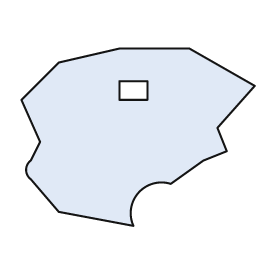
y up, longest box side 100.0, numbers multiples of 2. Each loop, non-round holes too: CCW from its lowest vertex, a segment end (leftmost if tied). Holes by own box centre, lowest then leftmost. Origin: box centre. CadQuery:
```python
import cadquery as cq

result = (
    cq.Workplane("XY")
    .moveTo(-2.0, -38.0)
    .threePointArc((0.0, -24.0), (14.0, -20.0))
    .lineTo(28.0, -10.0)
    .lineTo(38.0, -6.0)
    .lineTo(34.0, 4.0)
    .lineTo(50.0, 22.0)
    .lineTo(22.0, 38.0)
    .lineTo(-8.0, 38.0)
    .lineTo(-34.0, 32.0)
    .lineTo(-50.0, 16.0)
    .lineTo(-42.0, -2.0)
    .lineTo(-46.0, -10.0)
    .threePointArc((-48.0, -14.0), (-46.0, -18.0))
    .lineTo(-34.0, -32.0)
    .close()
    .moveTo(-8.0, 16.0)
    .lineTo(4.0, 16.0)
    .lineTo(4.0, 24.0)
    .lineTo(-8.0, 24.0)
    .close()
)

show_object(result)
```